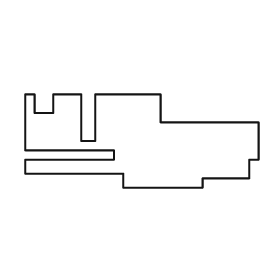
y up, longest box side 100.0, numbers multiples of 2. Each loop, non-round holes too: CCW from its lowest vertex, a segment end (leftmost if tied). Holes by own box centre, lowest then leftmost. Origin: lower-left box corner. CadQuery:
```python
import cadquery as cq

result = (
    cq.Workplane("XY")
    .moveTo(42.0, 0.0)
    .lineTo(76.0, 0.0)
    .lineTo(76.0, 4.0)
    .lineTo(96.0, 4.0)
    .lineTo(96.0, 12.0)
    .lineTo(100.0, 12.0)
    .lineTo(100.0, 28.0)
    .lineTo(58.0, 28.0)
    .lineTo(58.0, 40.0)
    .lineTo(30.0, 40.0)
    .lineTo(30.0, 20.0)
    .lineTo(24.0, 20.0)
    .lineTo(24.0, 40.0)
    .lineTo(12.0, 40.0)
    .lineTo(12.0, 32.0)
    .lineTo(4.0, 32.0)
    .lineTo(4.0, 40.0)
    .lineTo(0.0, 40.0)
    .lineTo(0.0, 16.0)
    .lineTo(38.0, 16.0)
    .lineTo(38.0, 12.0)
    .lineTo(0.0, 12.0)
    .lineTo(0.0, 6.0)
    .lineTo(42.0, 6.0)
    .close()
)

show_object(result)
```